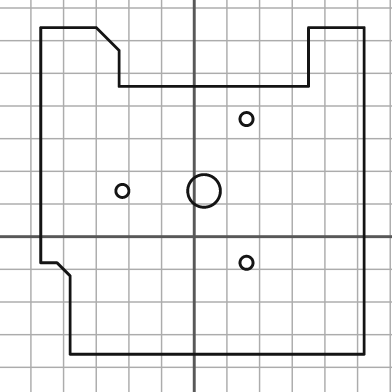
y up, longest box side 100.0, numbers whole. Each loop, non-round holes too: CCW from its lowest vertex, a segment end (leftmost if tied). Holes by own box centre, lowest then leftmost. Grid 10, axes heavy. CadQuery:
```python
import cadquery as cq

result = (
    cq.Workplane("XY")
    .moveTo(-38.0, -36.0)
    .lineTo(52.0, -36.0)
    .lineTo(52.0, 64.0)
    .lineTo(35.0, 64.0)
    .lineTo(35.0, 46.0)
    .lineTo(-23.0, 46.0)
    .lineTo(-23.0, 57.0)
    .lineTo(-30.0, 64.0)
    .lineTo(-47.0, 64.0)
    .lineTo(-47.0, -8.0)
    .lineTo(-42.0, -8.0)
    .lineTo(-38.0, -12.0)
    .close()
    .moveTo(16.0, -8.0)
    .circle(2.0)
    .moveTo(-22.0, 14.0)
    .circle(2.0)
    .moveTo(3.0, 14.0)
    .circle(5.0)
    .moveTo(16.0, 36.0)
    .circle(2.0)
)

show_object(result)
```